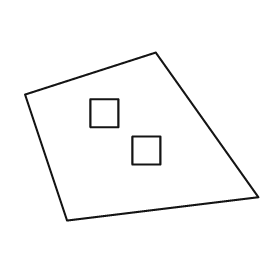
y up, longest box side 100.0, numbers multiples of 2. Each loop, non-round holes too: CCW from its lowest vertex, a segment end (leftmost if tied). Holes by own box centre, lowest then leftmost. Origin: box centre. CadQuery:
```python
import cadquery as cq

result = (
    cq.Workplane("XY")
    .moveTo(-32.0, -36.0)
    .lineTo(50.0, -26.0)
    .lineTo(6.0, 36.0)
    .lineTo(-50.0, 18.0)
    .close()
    .moveTo(-4.0, -12.0)
    .lineTo(8.0, -12.0)
    .lineTo(8.0, 0.0)
    .lineTo(-4.0, 0.0)
    .close()
    .moveTo(-22.0, 4.0)
    .lineTo(-10.0, 4.0)
    .lineTo(-10.0, 16.0)
    .lineTo(-22.0, 16.0)
    .close()
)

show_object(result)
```